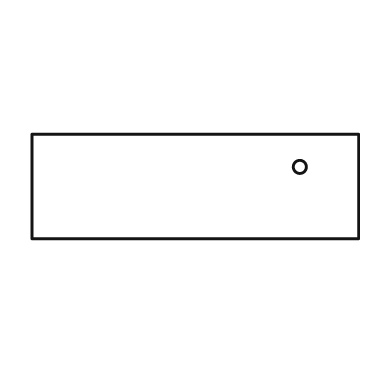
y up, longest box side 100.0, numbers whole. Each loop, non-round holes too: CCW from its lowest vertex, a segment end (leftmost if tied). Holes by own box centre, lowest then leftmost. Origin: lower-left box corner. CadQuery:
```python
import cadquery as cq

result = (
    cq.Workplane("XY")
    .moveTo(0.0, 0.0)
    .lineTo(100.0, 0.0)
    .lineTo(100.0, 32.0)
    .lineTo(0.0, 32.0)
    .close()
    .moveTo(82.0, 22.0)
    .circle(2.0)
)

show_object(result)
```